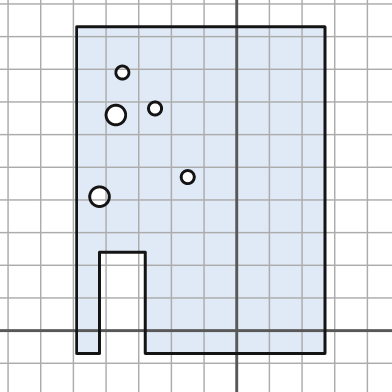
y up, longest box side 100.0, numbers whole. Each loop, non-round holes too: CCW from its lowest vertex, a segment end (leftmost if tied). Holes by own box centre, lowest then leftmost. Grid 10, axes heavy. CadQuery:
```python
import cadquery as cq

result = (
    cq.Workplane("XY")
    .moveTo(-49.0, -7.0)
    .lineTo(-42.0, -7.0)
    .lineTo(-42.0, 24.0)
    .lineTo(-28.0, 24.0)
    .lineTo(-28.0, -7.0)
    .lineTo(27.0, -7.0)
    .lineTo(27.0, 93.0)
    .lineTo(-49.0, 93.0)
    .close()
    .moveTo(-42.0, 41.0)
    .circle(3.0)
    .moveTo(-15.0, 47.0)
    .circle(2.0)
    .moveTo(-37.0, 66.0)
    .circle(3.0)
    .moveTo(-25.0, 68.0)
    .circle(2.0)
    .moveTo(-35.0, 79.0)
    .circle(2.0)
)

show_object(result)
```